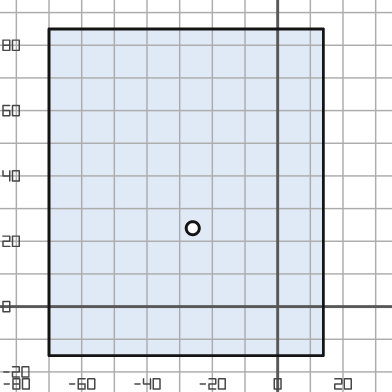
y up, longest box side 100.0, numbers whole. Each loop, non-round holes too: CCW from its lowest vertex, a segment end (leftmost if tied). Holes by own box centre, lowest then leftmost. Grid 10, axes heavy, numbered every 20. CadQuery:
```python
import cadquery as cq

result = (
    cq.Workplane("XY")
    .moveTo(-70.0, -15.0)
    .lineTo(14.0, -15.0)
    .lineTo(14.0, 85.0)
    .lineTo(-70.0, 85.0)
    .close()
    .moveTo(-26.0, 24.0)
    .circle(2.0)
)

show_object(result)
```